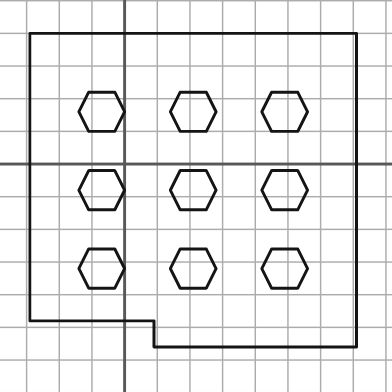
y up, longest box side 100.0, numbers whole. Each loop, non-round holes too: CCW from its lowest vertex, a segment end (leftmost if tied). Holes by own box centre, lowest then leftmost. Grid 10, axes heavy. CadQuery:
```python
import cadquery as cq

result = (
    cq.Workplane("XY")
    .moveTo(9.0, -56.0)
    .lineTo(71.0, -56.0)
    .lineTo(71.0, 40.0)
    .lineTo(-29.0, 40.0)
    .lineTo(-29.0, -48.0)
    .lineTo(9.0, -48.0)
    .close()
    .moveTo(-11.0, -38.0)
    .lineTo(-3.0, -38.0)
    .lineTo(0.0, -32.0)
    .lineTo(-3.0, -26.0)
    .lineTo(-11.0, -26.0)
    .lineTo(-14.0, -32.0)
    .close()
    .moveTo(17.0, -38.0)
    .lineTo(25.0, -38.0)
    .lineTo(28.0, -32.0)
    .lineTo(25.0, -26.0)
    .lineTo(17.0, -26.0)
    .lineTo(14.0, -32.0)
    .close()
    .moveTo(45.0, -38.0)
    .lineTo(53.0, -38.0)
    .lineTo(56.0, -32.0)
    .lineTo(53.0, -26.0)
    .lineTo(45.0, -26.0)
    .lineTo(42.0, -32.0)
    .close()
    .moveTo(-11.0, -14.0)
    .lineTo(-3.0, -14.0)
    .lineTo(0.0, -8.0)
    .lineTo(-3.0, -2.0)
    .lineTo(-11.0, -2.0)
    .lineTo(-14.0, -8.0)
    .close()
    .moveTo(17.0, -14.0)
    .lineTo(25.0, -14.0)
    .lineTo(28.0, -8.0)
    .lineTo(25.0, -2.0)
    .lineTo(17.0, -2.0)
    .lineTo(14.0, -8.0)
    .close()
    .moveTo(45.0, -14.0)
    .lineTo(53.0, -14.0)
    .lineTo(56.0, -8.0)
    .lineTo(53.0, -2.0)
    .lineTo(45.0, -2.0)
    .lineTo(42.0, -8.0)
    .close()
    .moveTo(-11.0, 10.0)
    .lineTo(-3.0, 10.0)
    .lineTo(0.0, 16.0)
    .lineTo(-3.0, 22.0)
    .lineTo(-11.0, 22.0)
    .lineTo(-14.0, 16.0)
    .close()
    .moveTo(17.0, 10.0)
    .lineTo(25.0, 10.0)
    .lineTo(28.0, 16.0)
    .lineTo(25.0, 22.0)
    .lineTo(17.0, 22.0)
    .lineTo(14.0, 16.0)
    .close()
    .moveTo(45.0, 10.0)
    .lineTo(53.0, 10.0)
    .lineTo(56.0, 16.0)
    .lineTo(53.0, 22.0)
    .lineTo(45.0, 22.0)
    .lineTo(42.0, 16.0)
    .close()
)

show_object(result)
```